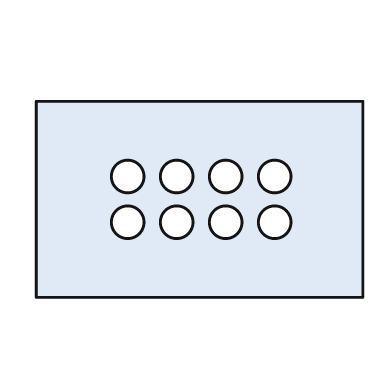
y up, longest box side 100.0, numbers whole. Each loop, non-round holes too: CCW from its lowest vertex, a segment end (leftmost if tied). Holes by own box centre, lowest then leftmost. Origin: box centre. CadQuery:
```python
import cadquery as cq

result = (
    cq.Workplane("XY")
    .moveTo(-50.0, -30.0)
    .lineTo(50.0, -30.0)
    .lineTo(50.0, 30.0)
    .lineTo(-50.0, 30.0)
    .close()
    .moveTo(-22.0, -7.0)
    .circle(5.0)
    .moveTo(-7.0, -7.0)
    .circle(5.0)
    .moveTo(8.0, -7.0)
    .circle(5.0)
    .moveTo(23.0, -7.0)
    .circle(5.0)
    .moveTo(-22.0, 7.0)
    .circle(5.0)
    .moveTo(-7.0, 7.0)
    .circle(5.0)
    .moveTo(8.0, 7.0)
    .circle(5.0)
    .moveTo(23.0, 7.0)
    .circle(5.0)
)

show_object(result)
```